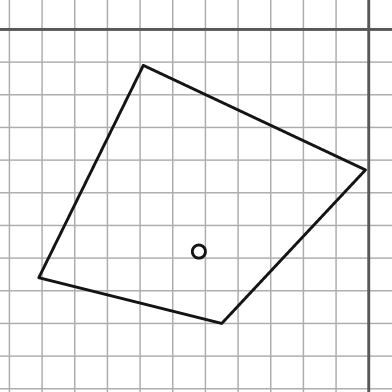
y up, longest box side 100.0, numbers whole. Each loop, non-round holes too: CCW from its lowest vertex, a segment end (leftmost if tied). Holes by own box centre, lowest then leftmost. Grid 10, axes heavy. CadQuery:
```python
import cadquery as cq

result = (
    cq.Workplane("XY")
    .moveTo(-45.0, -90.0)
    .lineTo(-1.0, -43.0)
    .lineTo(-69.0, -11.0)
    .lineTo(-101.0, -76.0)
    .close()
    .moveTo(-52.0, -68.0)
    .circle(2.0)
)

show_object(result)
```